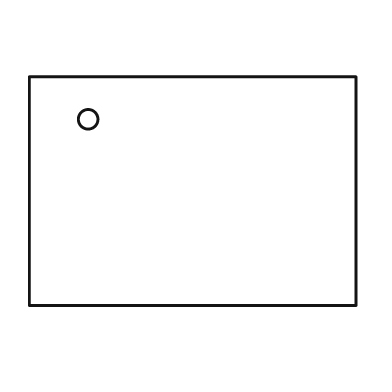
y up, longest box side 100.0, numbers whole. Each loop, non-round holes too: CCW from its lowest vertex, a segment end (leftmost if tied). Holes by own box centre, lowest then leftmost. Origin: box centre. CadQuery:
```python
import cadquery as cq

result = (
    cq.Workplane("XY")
    .moveTo(-50.0, -35.0)
    .lineTo(50.0, -35.0)
    .lineTo(50.0, 35.0)
    .lineTo(-50.0, 35.0)
    .close()
    .moveTo(-32.0, 22.0)
    .circle(3.0)
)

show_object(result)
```